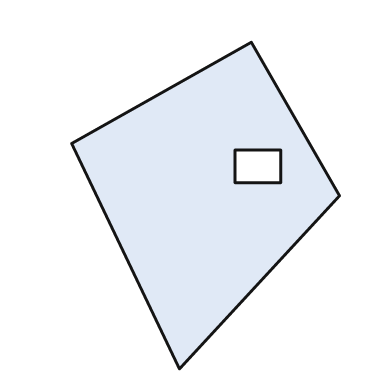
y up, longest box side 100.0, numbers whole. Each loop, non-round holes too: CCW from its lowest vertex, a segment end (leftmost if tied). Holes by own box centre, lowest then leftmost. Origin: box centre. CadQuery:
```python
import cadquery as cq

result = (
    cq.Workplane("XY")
    .moveTo(-8.0, -50.0)
    .lineTo(41.0, 3.0)
    .lineTo(14.0, 50.0)
    .lineTo(-41.0, 19.0)
    .close()
    .moveTo(9.0, 7.0)
    .lineTo(23.0, 7.0)
    .lineTo(23.0, 17.0)
    .lineTo(9.0, 17.0)
    .close()
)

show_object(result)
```